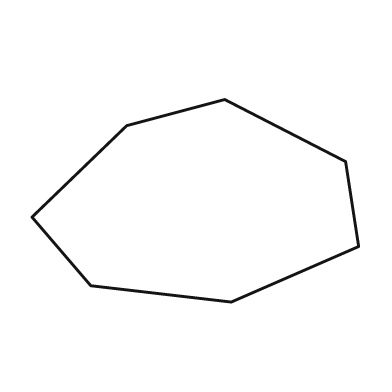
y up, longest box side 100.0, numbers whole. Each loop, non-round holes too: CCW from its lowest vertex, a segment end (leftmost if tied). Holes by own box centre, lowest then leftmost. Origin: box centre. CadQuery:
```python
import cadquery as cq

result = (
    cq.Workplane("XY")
    .moveTo(11.0, -31.0)
    .lineTo(50.0, -14.0)
    .lineTo(46.0, 12.0)
    .lineTo(9.0, 31.0)
    .lineTo(-21.0, 23.0)
    .lineTo(-50.0, -5.0)
    .lineTo(-32.0, -26.0)
    .close()
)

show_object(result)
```